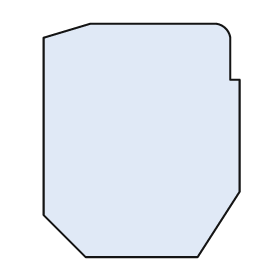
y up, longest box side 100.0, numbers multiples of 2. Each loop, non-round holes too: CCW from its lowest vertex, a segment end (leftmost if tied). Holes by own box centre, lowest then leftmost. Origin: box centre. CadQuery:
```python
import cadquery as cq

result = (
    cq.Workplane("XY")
    .moveTo(-24.0, -50.0)
    .lineTo(24.0, -50.0)
    .lineTo(42.0, -22.0)
    .lineTo(42.0, 26.0)
    .lineTo(38.0, 26.0)
    .lineTo(38.0, 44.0)
    .threePointArc((36.0, 48.0), (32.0, 50.0))
    .lineTo(-22.0, 50.0)
    .lineTo(-42.0, 44.0)
    .lineTo(-42.0, -32.0)
    .close()
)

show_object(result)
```